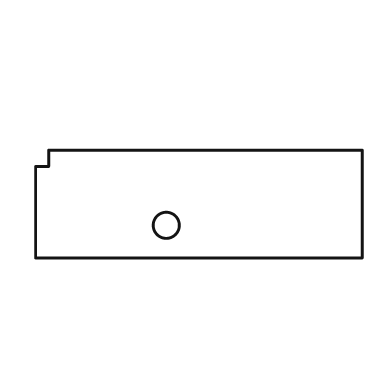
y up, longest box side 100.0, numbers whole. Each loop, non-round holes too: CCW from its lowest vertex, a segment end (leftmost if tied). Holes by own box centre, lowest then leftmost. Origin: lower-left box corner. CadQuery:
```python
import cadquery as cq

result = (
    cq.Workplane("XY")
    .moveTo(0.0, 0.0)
    .lineTo(100.0, 0.0)
    .lineTo(100.0, 33.0)
    .lineTo(4.0, 33.0)
    .lineTo(4.0, 28.0)
    .lineTo(0.0, 28.0)
    .close()
    .moveTo(40.0, 10.0)
    .circle(4.0)
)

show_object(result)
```